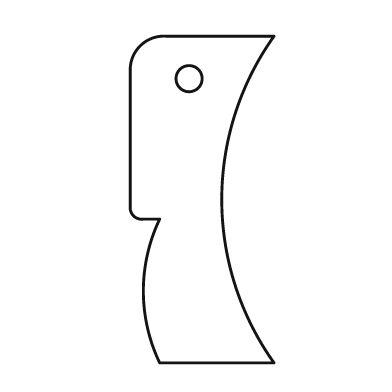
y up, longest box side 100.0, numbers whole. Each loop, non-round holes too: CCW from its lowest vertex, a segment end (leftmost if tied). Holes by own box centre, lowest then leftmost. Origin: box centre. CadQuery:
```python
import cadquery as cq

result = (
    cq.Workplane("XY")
    .moveTo(-13.0, -50.0)
    .lineTo(22.0, -50.0)
    .threePointArc((6.0, 0.0), (22.0, 50.0))
    .lineTo(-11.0, 50.0)
    .threePointArc((-19.0, 47.0), (-22.0, 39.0))
    .lineTo(-22.0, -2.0)
    .threePointArc((-21.0, -5.0), (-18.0, -6.0))
    .lineTo(-13.0, -6.0)
    .threePointArc((-18.0, -28.0), (-13.0, -50.0))
    .close()
    .moveTo(-4.0, 37.0)
    .circle(4.0)
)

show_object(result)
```